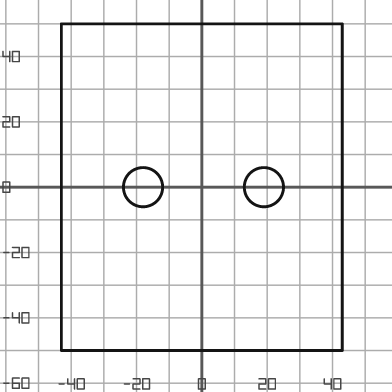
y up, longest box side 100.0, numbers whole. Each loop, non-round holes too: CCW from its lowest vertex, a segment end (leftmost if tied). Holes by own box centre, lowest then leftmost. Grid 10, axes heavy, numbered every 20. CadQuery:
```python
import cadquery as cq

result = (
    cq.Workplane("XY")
    .moveTo(-43.0, -50.0)
    .lineTo(43.0, -50.0)
    .lineTo(43.0, 50.0)
    .lineTo(-43.0, 50.0)
    .close()
    .moveTo(-18.0, 0.0)
    .circle(6.0)
    .moveTo(19.0, 0.0)
    .circle(6.0)
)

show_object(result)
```